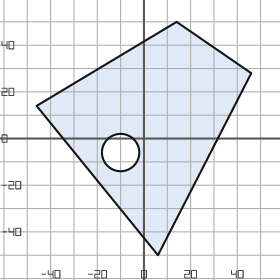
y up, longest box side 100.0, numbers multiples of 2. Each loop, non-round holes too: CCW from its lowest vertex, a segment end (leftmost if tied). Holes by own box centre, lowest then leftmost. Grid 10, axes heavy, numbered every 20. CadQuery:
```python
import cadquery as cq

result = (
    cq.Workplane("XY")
    .moveTo(6.0, -50.0)
    .lineTo(46.0, 28.0)
    .lineTo(14.0, 50.0)
    .lineTo(-46.0, 14.0)
    .close()
    .moveTo(-10.0, -6.0)
    .circle(8.0)
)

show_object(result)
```